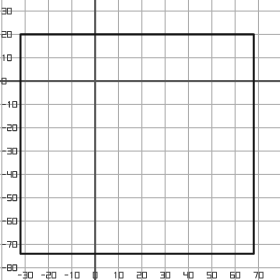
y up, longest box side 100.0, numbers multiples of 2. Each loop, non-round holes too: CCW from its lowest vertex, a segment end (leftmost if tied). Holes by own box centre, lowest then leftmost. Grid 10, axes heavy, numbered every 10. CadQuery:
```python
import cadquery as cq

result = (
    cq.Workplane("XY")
    .moveTo(-32.0, -74.0)
    .lineTo(68.0, -74.0)
    .lineTo(68.0, 20.0)
    .lineTo(-32.0, 20.0)
    .close()
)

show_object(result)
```